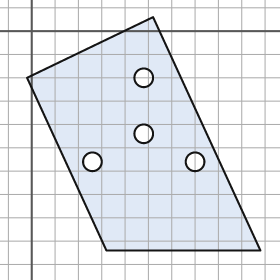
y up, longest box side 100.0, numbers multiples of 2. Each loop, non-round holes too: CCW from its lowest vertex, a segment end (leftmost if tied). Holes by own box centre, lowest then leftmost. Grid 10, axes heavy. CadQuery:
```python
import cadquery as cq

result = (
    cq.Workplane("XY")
    .moveTo(32.0, -94.0)
    .lineTo(98.0, -94.0)
    .lineTo(52.0, 6.0)
    .lineTo(-2.0, -20.0)
    .close()
    .moveTo(26.0, -56.0)
    .circle(4.0)
    .moveTo(70.0, -56.0)
    .circle(4.0)
    .moveTo(48.0, -44.0)
    .circle(4.0)
    .moveTo(48.0, -20.0)
    .circle(4.0)
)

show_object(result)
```